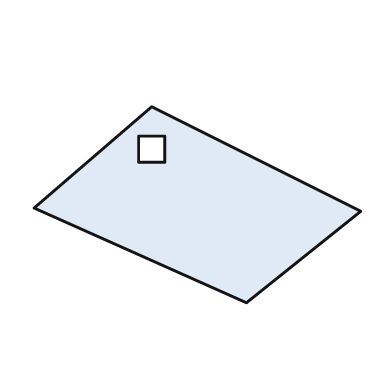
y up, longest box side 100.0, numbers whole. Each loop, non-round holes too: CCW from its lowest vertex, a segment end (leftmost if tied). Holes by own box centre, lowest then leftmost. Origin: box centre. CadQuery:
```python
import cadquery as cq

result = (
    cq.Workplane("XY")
    .moveTo(15.0, -30.0)
    .lineTo(50.0, -2.0)
    .lineTo(-14.0, 30.0)
    .lineTo(-50.0, -1.0)
    .close()
    .moveTo(-18.0, 13.0)
    .lineTo(-10.0, 13.0)
    .lineTo(-10.0, 21.0)
    .lineTo(-18.0, 21.0)
    .close()
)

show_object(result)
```